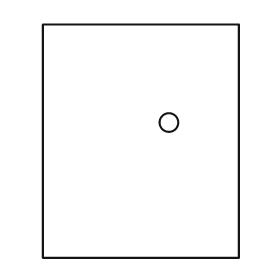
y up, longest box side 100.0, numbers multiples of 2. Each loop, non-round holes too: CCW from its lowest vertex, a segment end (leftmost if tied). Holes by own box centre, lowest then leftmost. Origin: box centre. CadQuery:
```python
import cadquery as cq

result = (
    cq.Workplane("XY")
    .moveTo(-42.0, -50.0)
    .lineTo(42.0, -50.0)
    .lineTo(42.0, 50.0)
    .lineTo(-42.0, 50.0)
    .close()
    .moveTo(12.0, 8.0)
    .circle(4.0)
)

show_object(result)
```